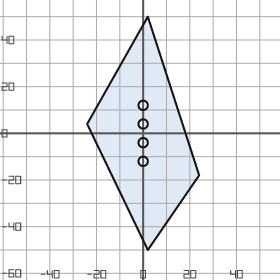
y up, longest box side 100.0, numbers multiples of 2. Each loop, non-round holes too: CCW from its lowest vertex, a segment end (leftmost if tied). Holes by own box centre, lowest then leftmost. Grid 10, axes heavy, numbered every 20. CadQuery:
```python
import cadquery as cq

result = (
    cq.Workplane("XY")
    .moveTo(2.0, -50.0)
    .lineTo(24.0, -18.0)
    .lineTo(2.0, 50.0)
    .lineTo(-24.0, 4.0)
    .close()
    .moveTo(0.0, -12.0)
    .circle(2.0)
    .moveTo(0.0, -4.0)
    .circle(2.0)
    .moveTo(0.0, 4.0)
    .circle(2.0)
    .moveTo(0.0, 12.0)
    .circle(2.0)
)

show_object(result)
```